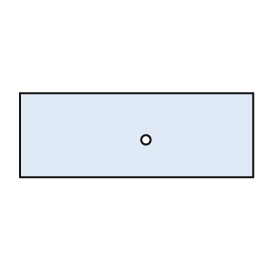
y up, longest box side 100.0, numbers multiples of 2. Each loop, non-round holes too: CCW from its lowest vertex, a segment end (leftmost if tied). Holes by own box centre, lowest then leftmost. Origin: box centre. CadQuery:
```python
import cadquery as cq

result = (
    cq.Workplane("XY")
    .moveTo(-50.0, -18.0)
    .lineTo(50.0, -18.0)
    .lineTo(50.0, 18.0)
    .lineTo(-50.0, 18.0)
    .close()
    .moveTo(4.0, -2.0)
    .circle(2.0)
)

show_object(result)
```